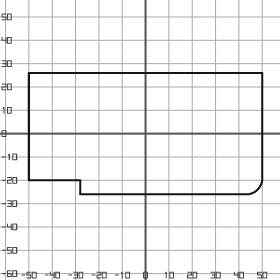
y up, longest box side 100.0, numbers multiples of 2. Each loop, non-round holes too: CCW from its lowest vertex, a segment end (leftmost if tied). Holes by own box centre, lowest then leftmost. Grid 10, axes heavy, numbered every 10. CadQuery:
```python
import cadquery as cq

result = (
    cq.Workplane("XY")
    .moveTo(-28.0, -26.0)
    .lineTo(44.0, -26.0)
    .threePointArc((48.0, -24.0), (50.0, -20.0))
    .lineTo(50.0, 26.0)
    .lineTo(-50.0, 26.0)
    .lineTo(-50.0, -20.0)
    .lineTo(-28.0, -20.0)
    .close()
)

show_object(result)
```